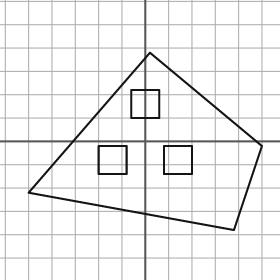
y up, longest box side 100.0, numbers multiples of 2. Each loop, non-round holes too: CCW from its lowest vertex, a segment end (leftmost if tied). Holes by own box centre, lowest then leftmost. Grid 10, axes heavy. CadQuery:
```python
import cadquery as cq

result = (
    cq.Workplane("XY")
    .moveTo(38.0, -38.0)
    .lineTo(50.0, -2.0)
    .lineTo(2.0, 38.0)
    .lineTo(-50.0, -22.0)
    .close()
    .moveTo(-20.0, -14.0)
    .lineTo(-8.0, -14.0)
    .lineTo(-8.0, -2.0)
    .lineTo(-20.0, -2.0)
    .close()
    .moveTo(8.0, -14.0)
    .lineTo(20.0, -14.0)
    .lineTo(20.0, -2.0)
    .lineTo(8.0, -2.0)
    .close()
    .moveTo(-6.0, 10.0)
    .lineTo(6.0, 10.0)
    .lineTo(6.0, 22.0)
    .lineTo(-6.0, 22.0)
    .close()
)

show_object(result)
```